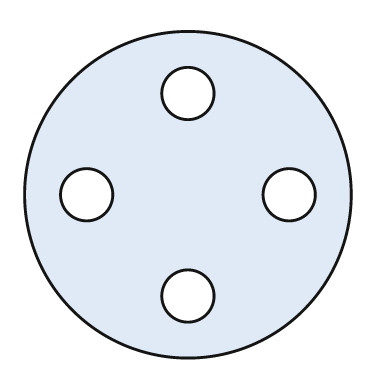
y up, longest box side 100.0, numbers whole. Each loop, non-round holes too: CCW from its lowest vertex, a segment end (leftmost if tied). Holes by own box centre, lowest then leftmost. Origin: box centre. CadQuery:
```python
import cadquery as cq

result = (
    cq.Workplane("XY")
    .moveTo(0.0, 0.0)
    .circle(50.0)
    .moveTo(0.0, -31.0)
    .circle(8.0)
    .moveTo(-31.0, 0.0)
    .circle(8.0)
    .moveTo(31.0, 0.0)
    .circle(8.0)
    .moveTo(0.0, 31.0)
    .circle(8.0)
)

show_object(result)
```